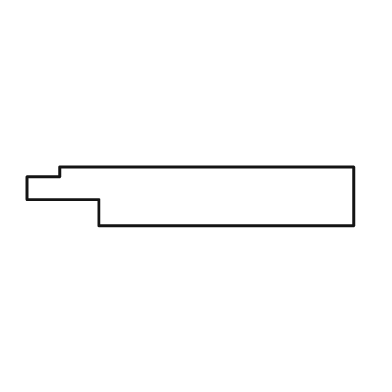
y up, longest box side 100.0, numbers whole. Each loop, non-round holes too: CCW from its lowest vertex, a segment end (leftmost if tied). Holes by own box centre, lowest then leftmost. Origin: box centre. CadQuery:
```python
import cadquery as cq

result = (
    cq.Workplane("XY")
    .moveTo(-28.0, -9.0)
    .lineTo(50.0, -9.0)
    .lineTo(50.0, 9.0)
    .lineTo(-40.0, 9.0)
    .lineTo(-40.0, 6.0)
    .lineTo(-50.0, 6.0)
    .lineTo(-50.0, -1.0)
    .lineTo(-28.0, -1.0)
    .close()
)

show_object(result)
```